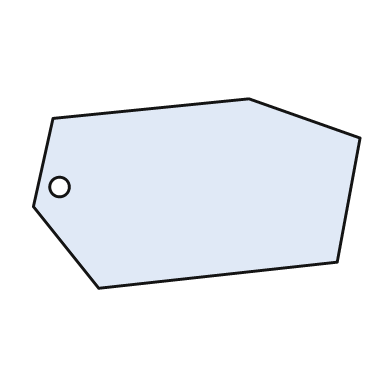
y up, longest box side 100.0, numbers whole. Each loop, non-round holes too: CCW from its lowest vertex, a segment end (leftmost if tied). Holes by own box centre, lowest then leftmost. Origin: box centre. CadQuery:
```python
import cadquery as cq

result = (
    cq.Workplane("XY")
    .moveTo(-30.0, -29.0)
    .lineTo(43.0, -21.0)
    .lineTo(50.0, 17.0)
    .lineTo(16.0, 29.0)
    .lineTo(-44.0, 23.0)
    .lineTo(-50.0, -4.0)
    .close()
    .moveTo(-42.0, 2.0)
    .circle(3.0)
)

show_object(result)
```